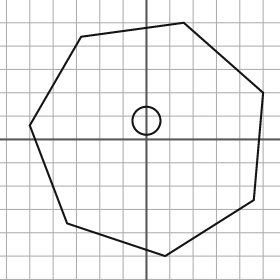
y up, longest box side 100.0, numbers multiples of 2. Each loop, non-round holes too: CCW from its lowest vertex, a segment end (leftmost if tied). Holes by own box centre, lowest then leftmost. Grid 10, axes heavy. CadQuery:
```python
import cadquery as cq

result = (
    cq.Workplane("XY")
    .moveTo(8.0, -50.0)
    .lineTo(46.0, -26.0)
    .lineTo(50.0, 20.0)
    .lineTo(16.0, 50.0)
    .lineTo(-28.0, 44.0)
    .lineTo(-50.0, 6.0)
    .lineTo(-34.0, -36.0)
    .close()
    .moveTo(0.0, 8.0)
    .circle(6.0)
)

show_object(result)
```